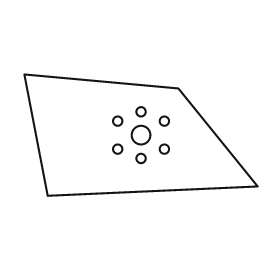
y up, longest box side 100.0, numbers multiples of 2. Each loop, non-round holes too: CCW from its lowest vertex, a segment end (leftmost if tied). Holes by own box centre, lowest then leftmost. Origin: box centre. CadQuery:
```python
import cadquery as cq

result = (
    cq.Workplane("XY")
    .moveTo(-40.0, -26.0)
    .lineTo(50.0, -22.0)
    .lineTo(16.0, 20.0)
    .lineTo(-50.0, 26.0)
    .close()
    .moveTo(0.0, -10.0)
    .circle(2.0)
    .moveTo(-10.0, -6.0)
    .circle(2.0)
    .moveTo(10.0, -6.0)
    .circle(2.0)
    .moveTo(0.0, 0.0)
    .circle(4.0)
    .moveTo(-10.0, 6.0)
    .circle(2.0)
    .moveTo(10.0, 6.0)
    .circle(2.0)
    .moveTo(0.0, 10.0)
    .circle(2.0)
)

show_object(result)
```